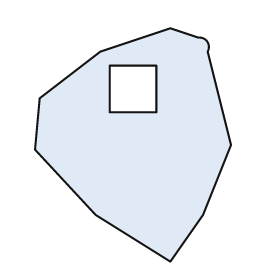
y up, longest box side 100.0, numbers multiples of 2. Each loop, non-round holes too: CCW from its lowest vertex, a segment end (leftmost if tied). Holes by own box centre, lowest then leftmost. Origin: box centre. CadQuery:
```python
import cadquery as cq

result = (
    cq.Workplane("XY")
    .moveTo(16.0, -50.0)
    .lineTo(30.0, -30.0)
    .lineTo(42.0, 0.0)
    .lineTo(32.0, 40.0)
    .threePointArc((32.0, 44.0), (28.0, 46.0))
    .lineTo(16.0, 50.0)
    .lineTo(-14.0, 40.0)
    .lineTo(-40.0, 20.0)
    .lineTo(-42.0, -2.0)
    .lineTo(-16.0, -30.0)
    .close()
    .moveTo(-10.0, 14.0)
    .lineTo(10.0, 14.0)
    .lineTo(10.0, 34.0)
    .lineTo(-10.0, 34.0)
    .close()
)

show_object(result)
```